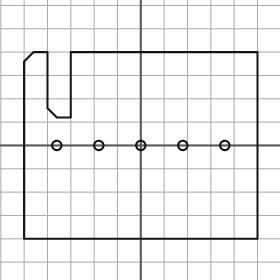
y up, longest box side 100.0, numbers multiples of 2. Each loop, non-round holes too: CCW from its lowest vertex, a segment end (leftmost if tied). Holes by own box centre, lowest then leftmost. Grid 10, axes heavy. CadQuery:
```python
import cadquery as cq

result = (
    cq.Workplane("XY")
    .moveTo(-50.0, -40.0)
    .lineTo(50.0, -40.0)
    .lineTo(50.0, 40.0)
    .lineTo(-30.0, 40.0)
    .lineTo(-30.0, 12.0)
    .lineTo(-36.0, 12.0)
    .lineTo(-40.0, 16.0)
    .lineTo(-40.0, 40.0)
    .lineTo(-46.0, 40.0)
    .lineTo(-50.0, 36.0)
    .close()
    .moveTo(-36.0, 0.0)
    .circle(2.0)
    .moveTo(-18.0, 0.0)
    .circle(2.0)
    .moveTo(0.0, 0.0)
    .circle(2.0)
    .moveTo(18.0, 0.0)
    .circle(2.0)
    .moveTo(36.0, 0.0)
    .circle(2.0)
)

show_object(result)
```